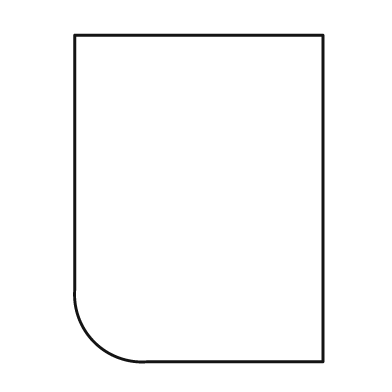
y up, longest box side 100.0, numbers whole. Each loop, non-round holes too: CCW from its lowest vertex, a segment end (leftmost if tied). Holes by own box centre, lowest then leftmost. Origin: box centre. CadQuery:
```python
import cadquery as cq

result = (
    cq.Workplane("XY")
    .moveTo(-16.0, -50.0)
    .lineTo(38.0, -50.0)
    .lineTo(38.0, 50.0)
    .lineTo(-38.0, 50.0)
    .lineTo(-38.0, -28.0)
    .threePointArc((-32.0, -44.0), (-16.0, -50.0))
    .close()
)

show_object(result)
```